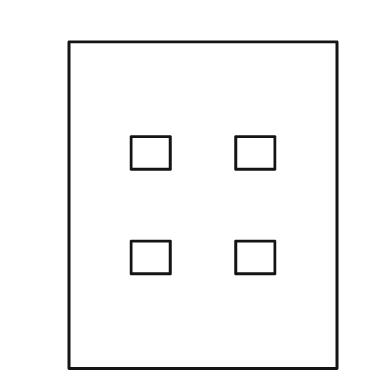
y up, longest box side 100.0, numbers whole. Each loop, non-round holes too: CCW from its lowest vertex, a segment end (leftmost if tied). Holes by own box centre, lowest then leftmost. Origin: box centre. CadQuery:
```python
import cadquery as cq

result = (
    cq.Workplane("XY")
    .moveTo(-41.0, -50.0)
    .lineTo(41.0, -50.0)
    .lineTo(41.0, 50.0)
    .lineTo(-41.0, 50.0)
    .close()
    .moveTo(-22.0, -21.0)
    .lineTo(-10.0, -21.0)
    .lineTo(-10.0, -11.0)
    .lineTo(-22.0, -11.0)
    .close()
    .moveTo(10.0, -21.0)
    .lineTo(22.0, -21.0)
    .lineTo(22.0, -11.0)
    .lineTo(10.0, -11.0)
    .close()
    .moveTo(-22.0, 11.0)
    .lineTo(-10.0, 11.0)
    .lineTo(-10.0, 21.0)
    .lineTo(-22.0, 21.0)
    .close()
    .moveTo(10.0, 11.0)
    .lineTo(22.0, 11.0)
    .lineTo(22.0, 21.0)
    .lineTo(10.0, 21.0)
    .close()
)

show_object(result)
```